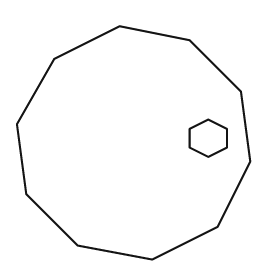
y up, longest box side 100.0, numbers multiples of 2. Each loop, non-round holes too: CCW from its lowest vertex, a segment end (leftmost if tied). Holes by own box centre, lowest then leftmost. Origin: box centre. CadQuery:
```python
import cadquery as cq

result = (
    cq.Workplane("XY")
    .moveTo(8.0, -50.0)
    .lineTo(36.0, -36.0)
    .lineTo(50.0, -8.0)
    .lineTo(46.0, 22.0)
    .lineTo(24.0, 44.0)
    .lineTo(-6.0, 50.0)
    .lineTo(-34.0, 36.0)
    .lineTo(-50.0, 8.0)
    .lineTo(-46.0, -22.0)
    .lineTo(-24.0, -44.0)
    .close()
    .moveTo(32.0, -6.0)
    .lineTo(40.0, -2.0)
    .lineTo(40.0, 6.0)
    .lineTo(32.0, 10.0)
    .lineTo(24.0, 6.0)
    .lineTo(24.0, -2.0)
    .close()
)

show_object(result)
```